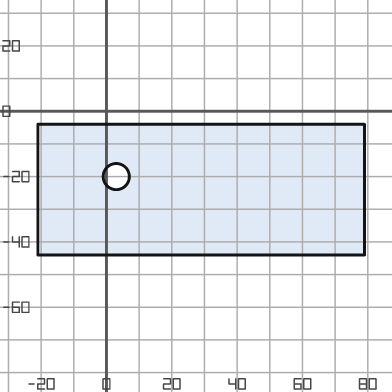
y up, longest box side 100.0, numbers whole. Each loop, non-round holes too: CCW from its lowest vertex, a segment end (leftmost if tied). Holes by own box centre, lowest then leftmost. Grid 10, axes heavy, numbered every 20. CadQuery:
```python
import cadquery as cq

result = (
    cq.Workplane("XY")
    .moveTo(-21.0, -44.0)
    .lineTo(79.0, -44.0)
    .lineTo(79.0, -4.0)
    .lineTo(-21.0, -4.0)
    .close()
    .moveTo(3.0, -20.0)
    .circle(4.0)
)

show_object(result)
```